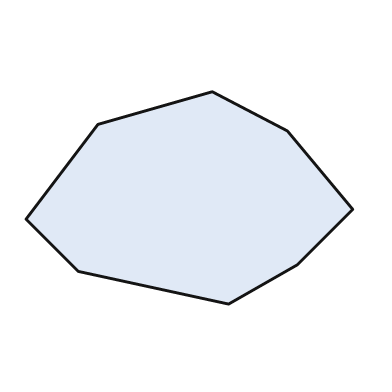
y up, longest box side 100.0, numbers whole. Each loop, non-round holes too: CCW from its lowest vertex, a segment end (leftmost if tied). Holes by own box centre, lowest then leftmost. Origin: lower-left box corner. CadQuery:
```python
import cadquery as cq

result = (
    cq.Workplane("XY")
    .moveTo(62.0, 0.0)
    .lineTo(83.0, 12.0)
    .lineTo(100.0, 29.0)
    .lineTo(80.0, 53.0)
    .lineTo(57.0, 65.0)
    .lineTo(22.0, 55.0)
    .lineTo(0.0, 26.0)
    .lineTo(16.0, 10.0)
    .close()
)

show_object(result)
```